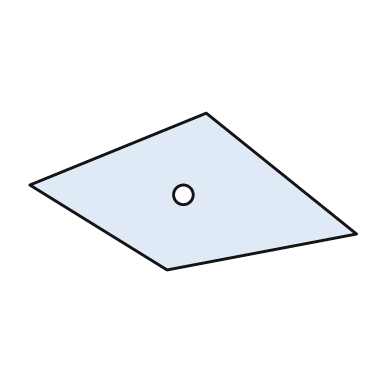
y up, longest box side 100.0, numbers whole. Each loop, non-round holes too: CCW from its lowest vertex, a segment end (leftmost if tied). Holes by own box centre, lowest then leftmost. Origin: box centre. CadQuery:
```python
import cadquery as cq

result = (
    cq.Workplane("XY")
    .moveTo(-8.0, -24.0)
    .lineTo(50.0, -13.0)
    .lineTo(4.0, 24.0)
    .lineTo(-50.0, 2.0)
    .close()
    .moveTo(-3.0, -1.0)
    .circle(3.0)
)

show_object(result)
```